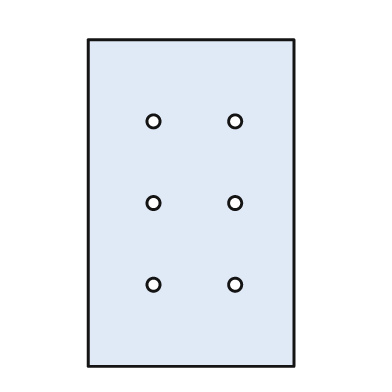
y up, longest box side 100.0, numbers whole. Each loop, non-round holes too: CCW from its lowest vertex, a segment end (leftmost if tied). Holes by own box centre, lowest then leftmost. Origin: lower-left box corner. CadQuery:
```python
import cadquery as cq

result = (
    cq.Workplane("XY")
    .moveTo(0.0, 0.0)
    .lineTo(63.0, 0.0)
    .lineTo(63.0, 100.0)
    .lineTo(0.0, 100.0)
    .close()
    .moveTo(20.0, 25.0)
    .circle(2.0)
    .moveTo(45.0, 25.0)
    .circle(2.0)
    .moveTo(20.0, 50.0)
    .circle(2.0)
    .moveTo(45.0, 50.0)
    .circle(2.0)
    .moveTo(20.0, 75.0)
    .circle(2.0)
    .moveTo(45.0, 75.0)
    .circle(2.0)
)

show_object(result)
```